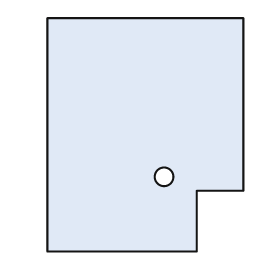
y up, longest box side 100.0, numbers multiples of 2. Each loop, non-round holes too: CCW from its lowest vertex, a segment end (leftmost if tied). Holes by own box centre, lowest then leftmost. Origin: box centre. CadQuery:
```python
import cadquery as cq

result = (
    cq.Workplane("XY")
    .moveTo(-42.0, -50.0)
    .lineTo(22.0, -50.0)
    .lineTo(22.0, -24.0)
    .lineTo(42.0, -24.0)
    .lineTo(42.0, 50.0)
    .lineTo(-42.0, 50.0)
    .close()
    .moveTo(8.0, -18.0)
    .circle(4.0)
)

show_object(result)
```